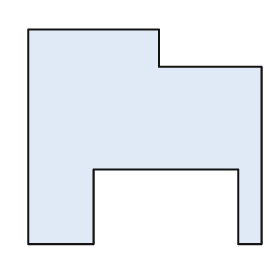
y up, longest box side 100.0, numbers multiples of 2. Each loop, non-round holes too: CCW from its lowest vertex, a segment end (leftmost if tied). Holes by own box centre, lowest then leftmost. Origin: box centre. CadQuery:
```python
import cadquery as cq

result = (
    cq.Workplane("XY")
    .moveTo(-50.0, -46.0)
    .lineTo(-22.0, -46.0)
    .lineTo(-22.0, -14.0)
    .lineTo(40.0, -14.0)
    .lineTo(40.0, -46.0)
    .lineTo(50.0, -46.0)
    .lineTo(50.0, 30.0)
    .lineTo(6.0, 30.0)
    .lineTo(6.0, 46.0)
    .lineTo(-50.0, 46.0)
    .close()
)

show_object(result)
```